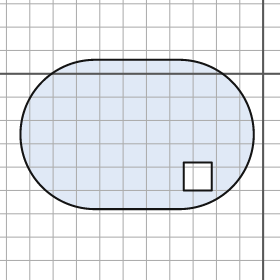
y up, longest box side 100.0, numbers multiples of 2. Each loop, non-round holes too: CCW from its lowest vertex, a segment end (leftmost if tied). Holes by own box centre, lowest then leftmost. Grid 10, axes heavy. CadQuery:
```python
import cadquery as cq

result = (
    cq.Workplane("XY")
    .moveTo(-72.0, -58.0)
    .lineTo(-36.0, -58.0)
    .threePointArc((-4.0, -26.0), (-36.0, 6.0))
    .lineTo(-72.0, 6.0)
    .threePointArc((-104.0, -26.0), (-72.0, -58.0))
    .close()
    .moveTo(-34.0, -50.0)
    .lineTo(-22.0, -50.0)
    .lineTo(-22.0, -38.0)
    .lineTo(-34.0, -38.0)
    .close()
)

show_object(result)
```